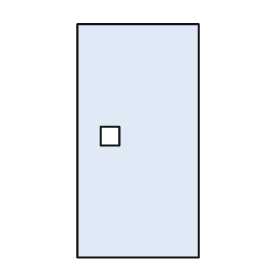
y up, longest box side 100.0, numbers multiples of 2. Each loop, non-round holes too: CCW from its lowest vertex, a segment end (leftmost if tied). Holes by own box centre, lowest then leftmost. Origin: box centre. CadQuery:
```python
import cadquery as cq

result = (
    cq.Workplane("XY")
    .moveTo(-26.0, -50.0)
    .lineTo(26.0, -50.0)
    .lineTo(26.0, 50.0)
    .lineTo(-26.0, 50.0)
    .close()
    .moveTo(-16.0, -2.0)
    .lineTo(-8.0, -2.0)
    .lineTo(-8.0, 6.0)
    .lineTo(-16.0, 6.0)
    .close()
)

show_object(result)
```